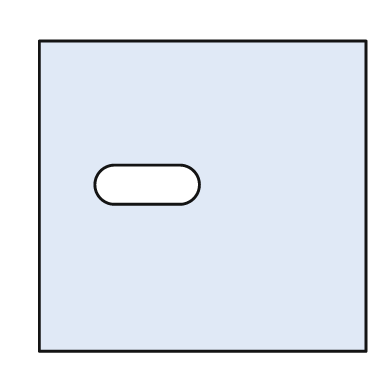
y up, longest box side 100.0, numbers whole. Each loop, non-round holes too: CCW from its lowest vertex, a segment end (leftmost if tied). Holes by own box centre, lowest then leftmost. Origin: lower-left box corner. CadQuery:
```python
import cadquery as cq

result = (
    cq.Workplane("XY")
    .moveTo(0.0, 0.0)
    .lineTo(100.0, 0.0)
    .lineTo(100.0, 95.0)
    .lineTo(0.0, 95.0)
    .close()
    .moveTo(23.0, 45.0)
    .lineTo(43.0, 45.0)
    .threePointArc((49.0, 51.0), (43.0, 57.0))
    .lineTo(23.0, 57.0)
    .threePointArc((17.0, 51.0), (23.0, 45.0))
    .close()
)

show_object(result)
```